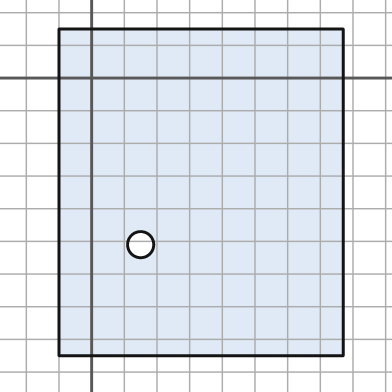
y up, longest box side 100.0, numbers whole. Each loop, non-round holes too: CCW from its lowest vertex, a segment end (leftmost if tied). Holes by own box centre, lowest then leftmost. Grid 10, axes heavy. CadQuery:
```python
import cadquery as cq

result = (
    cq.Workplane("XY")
    .moveTo(-10.0, -85.0)
    .lineTo(77.0, -85.0)
    .lineTo(77.0, 15.0)
    .lineTo(-10.0, 15.0)
    .close()
    .moveTo(15.0, -51.0)
    .circle(4.0)
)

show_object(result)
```